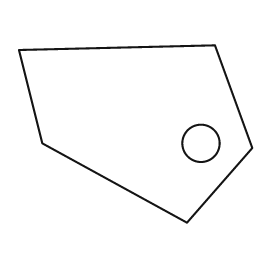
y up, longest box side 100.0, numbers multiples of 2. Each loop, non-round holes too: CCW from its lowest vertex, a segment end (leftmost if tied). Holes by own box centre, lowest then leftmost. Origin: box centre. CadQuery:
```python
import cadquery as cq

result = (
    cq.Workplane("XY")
    .moveTo(22.0, -38.0)
    .lineTo(50.0, -6.0)
    .lineTo(34.0, 38.0)
    .lineTo(-50.0, 36.0)
    .lineTo(-40.0, -4.0)
    .close()
    .moveTo(28.0, -4.0)
    .circle(8.0)
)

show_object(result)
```